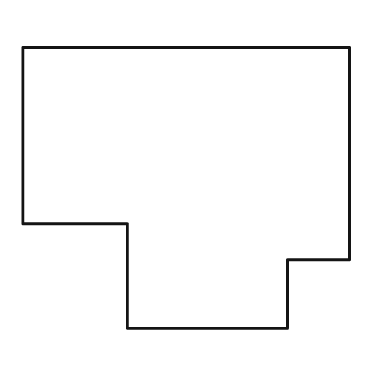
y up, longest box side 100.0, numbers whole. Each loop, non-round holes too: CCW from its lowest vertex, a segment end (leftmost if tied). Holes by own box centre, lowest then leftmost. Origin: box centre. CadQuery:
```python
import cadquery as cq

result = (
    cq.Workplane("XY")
    .moveTo(-18.0, -43.0)
    .lineTo(31.0, -43.0)
    .lineTo(31.0, -22.0)
    .lineTo(50.0, -22.0)
    .lineTo(50.0, 43.0)
    .lineTo(-50.0, 43.0)
    .lineTo(-50.0, -11.0)
    .lineTo(-18.0, -11.0)
    .close()
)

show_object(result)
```